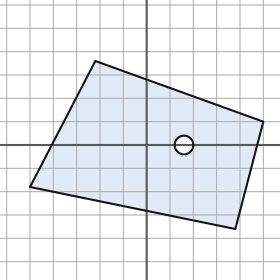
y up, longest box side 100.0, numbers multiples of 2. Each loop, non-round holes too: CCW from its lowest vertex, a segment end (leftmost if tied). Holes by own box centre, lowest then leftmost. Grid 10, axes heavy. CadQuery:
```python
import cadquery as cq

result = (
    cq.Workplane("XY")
    .moveTo(38.0, -36.0)
    .lineTo(50.0, 10.0)
    .lineTo(-22.0, 36.0)
    .lineTo(-50.0, -18.0)
    .close()
    .moveTo(16.0, 0.0)
    .circle(4.0)
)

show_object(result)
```